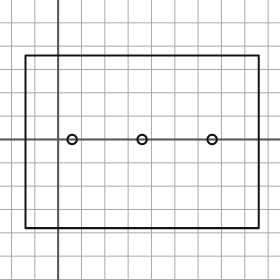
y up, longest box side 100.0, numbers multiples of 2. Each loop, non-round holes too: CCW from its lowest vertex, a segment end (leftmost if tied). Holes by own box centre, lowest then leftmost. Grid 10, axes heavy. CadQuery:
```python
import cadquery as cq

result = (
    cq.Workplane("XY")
    .moveTo(-14.0, -38.0)
    .lineTo(86.0, -38.0)
    .lineTo(86.0, 36.0)
    .lineTo(-14.0, 36.0)
    .close()
    .moveTo(6.0, 0.0)
    .circle(2.0)
    .moveTo(36.0, 0.0)
    .circle(2.0)
    .moveTo(66.0, 0.0)
    .circle(2.0)
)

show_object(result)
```